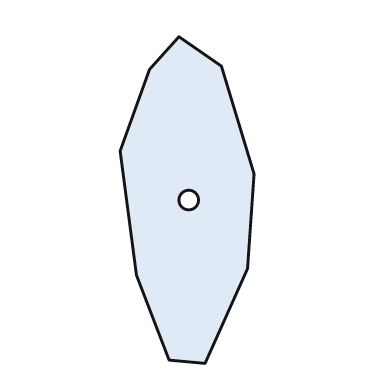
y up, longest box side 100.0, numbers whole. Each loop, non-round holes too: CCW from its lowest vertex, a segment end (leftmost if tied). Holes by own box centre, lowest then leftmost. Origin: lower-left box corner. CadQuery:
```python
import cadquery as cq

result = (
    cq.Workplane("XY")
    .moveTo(26.0, 0.0)
    .lineTo(39.0, 29.0)
    .lineTo(41.0, 58.0)
    .lineTo(31.0, 91.0)
    .lineTo(18.0, 100.0)
    .lineTo(9.0, 90.0)
    .lineTo(0.0, 65.0)
    .lineTo(5.0, 27.0)
    .lineTo(15.0, 1.0)
    .close()
    .moveTo(21.0, 50.0)
    .circle(3.0)
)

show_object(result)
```